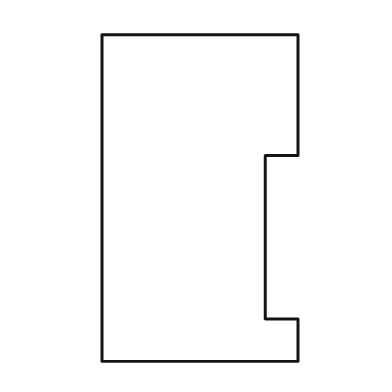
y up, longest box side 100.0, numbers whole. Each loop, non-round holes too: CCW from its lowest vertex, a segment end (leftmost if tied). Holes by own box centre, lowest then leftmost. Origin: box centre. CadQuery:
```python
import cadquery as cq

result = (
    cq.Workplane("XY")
    .moveTo(-30.0, -50.0)
    .lineTo(30.0, -50.0)
    .lineTo(30.0, -37.0)
    .lineTo(20.0, -37.0)
    .lineTo(20.0, 13.0)
    .lineTo(30.0, 13.0)
    .lineTo(30.0, 50.0)
    .lineTo(-30.0, 50.0)
    .close()
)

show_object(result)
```